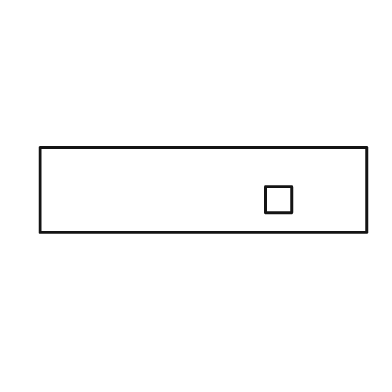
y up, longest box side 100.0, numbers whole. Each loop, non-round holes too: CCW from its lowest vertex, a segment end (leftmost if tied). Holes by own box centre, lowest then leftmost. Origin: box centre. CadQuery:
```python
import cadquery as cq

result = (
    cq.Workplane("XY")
    .moveTo(-50.0, -13.0)
    .lineTo(50.0, -13.0)
    .lineTo(50.0, 13.0)
    .lineTo(-50.0, 13.0)
    .close()
    .moveTo(19.0, -7.0)
    .lineTo(27.0, -7.0)
    .lineTo(27.0, 1.0)
    .lineTo(19.0, 1.0)
    .close()
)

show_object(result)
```